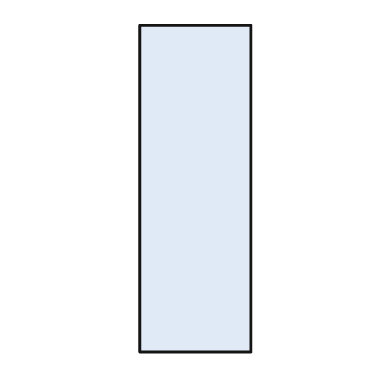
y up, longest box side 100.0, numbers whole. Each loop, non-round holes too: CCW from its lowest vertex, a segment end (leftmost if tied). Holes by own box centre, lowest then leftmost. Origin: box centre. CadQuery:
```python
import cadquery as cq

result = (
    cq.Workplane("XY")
    .moveTo(-17.0, -50.0)
    .lineTo(17.0, -50.0)
    .lineTo(17.0, 50.0)
    .lineTo(-17.0, 50.0)
    .close()
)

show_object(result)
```